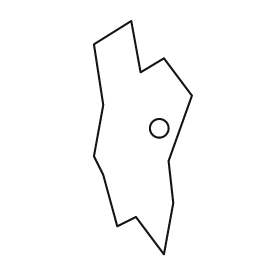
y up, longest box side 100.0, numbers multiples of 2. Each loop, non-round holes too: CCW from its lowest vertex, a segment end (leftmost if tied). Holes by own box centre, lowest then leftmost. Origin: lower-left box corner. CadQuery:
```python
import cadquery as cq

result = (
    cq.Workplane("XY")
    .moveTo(30.0, 0.0)
    .lineTo(34.0, 22.0)
    .lineTo(32.0, 40.0)
    .lineTo(42.0, 68.0)
    .lineTo(30.0, 84.0)
    .lineTo(20.0, 78.0)
    .lineTo(16.0, 100.0)
    .lineTo(0.0, 90.0)
    .lineTo(4.0, 64.0)
    .lineTo(0.0, 42.0)
    .lineTo(4.0, 34.0)
    .lineTo(10.0, 12.0)
    .lineTo(18.0, 16.0)
    .close()
    .moveTo(28.0, 54.0)
    .circle(4.0)
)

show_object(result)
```